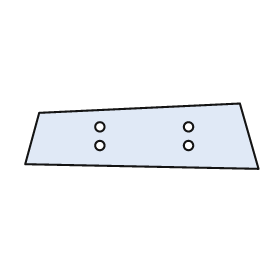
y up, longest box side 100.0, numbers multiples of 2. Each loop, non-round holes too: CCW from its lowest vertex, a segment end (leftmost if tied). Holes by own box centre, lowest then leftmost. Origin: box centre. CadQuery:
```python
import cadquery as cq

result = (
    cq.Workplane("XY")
    .moveTo(50.0, -14.0)
    .lineTo(42.0, 14.0)
    .lineTo(-44.0, 10.0)
    .lineTo(-50.0, -12.0)
    .close()
    .moveTo(-18.0, -4.0)
    .circle(2.0)
    .moveTo(20.0, -4.0)
    .circle(2.0)
    .moveTo(-18.0, 4.0)
    .circle(2.0)
    .moveTo(20.0, 4.0)
    .circle(2.0)
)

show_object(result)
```